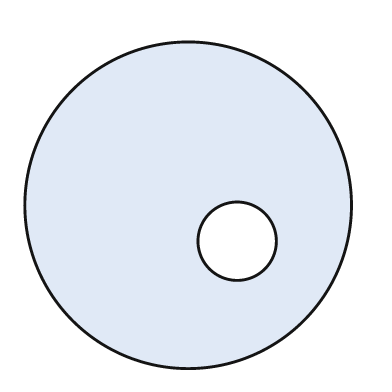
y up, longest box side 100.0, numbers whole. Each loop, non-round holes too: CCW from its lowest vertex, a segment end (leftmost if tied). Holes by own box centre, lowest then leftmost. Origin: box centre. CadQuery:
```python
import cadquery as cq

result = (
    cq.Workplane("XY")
    .moveTo(0.0, 0.0)
    .circle(50.0)
    .moveTo(15.0, -11.0)
    .circle(12.0)
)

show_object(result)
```